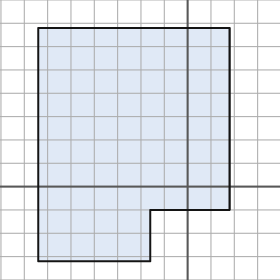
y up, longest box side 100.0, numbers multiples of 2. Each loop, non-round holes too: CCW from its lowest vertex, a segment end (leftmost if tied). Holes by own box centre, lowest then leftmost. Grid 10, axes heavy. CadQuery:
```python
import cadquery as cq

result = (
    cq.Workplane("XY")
    .moveTo(-64.0, -32.0)
    .lineTo(-16.0, -32.0)
    .lineTo(-16.0, -10.0)
    .lineTo(18.0, -10.0)
    .lineTo(18.0, 68.0)
    .lineTo(-64.0, 68.0)
    .close()
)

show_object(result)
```